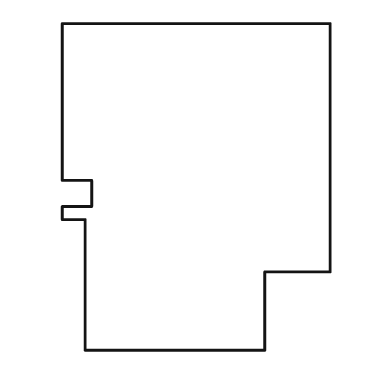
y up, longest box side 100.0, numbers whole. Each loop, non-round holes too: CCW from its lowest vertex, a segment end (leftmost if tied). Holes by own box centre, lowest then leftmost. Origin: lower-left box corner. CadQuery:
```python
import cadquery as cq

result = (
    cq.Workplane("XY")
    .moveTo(7.0, 0.0)
    .lineTo(62.0, 0.0)
    .lineTo(62.0, 24.0)
    .lineTo(82.0, 24.0)
    .lineTo(82.0, 100.0)
    .lineTo(0.0, 100.0)
    .lineTo(0.0, 52.0)
    .lineTo(9.0, 52.0)
    .lineTo(9.0, 44.0)
    .lineTo(0.0, 44.0)
    .lineTo(0.0, 40.0)
    .lineTo(7.0, 40.0)
    .close()
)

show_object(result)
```